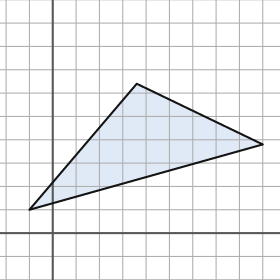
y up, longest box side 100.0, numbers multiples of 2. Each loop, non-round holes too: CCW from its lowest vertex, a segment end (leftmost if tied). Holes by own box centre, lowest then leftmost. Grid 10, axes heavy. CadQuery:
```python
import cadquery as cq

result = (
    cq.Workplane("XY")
    .moveTo(-10.0, 10.0)
    .lineTo(90.0, 38.0)
    .lineTo(36.0, 64.0)
    .close()
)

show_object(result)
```